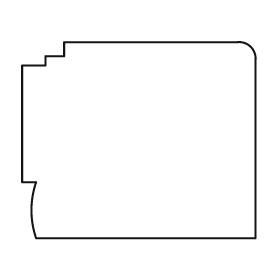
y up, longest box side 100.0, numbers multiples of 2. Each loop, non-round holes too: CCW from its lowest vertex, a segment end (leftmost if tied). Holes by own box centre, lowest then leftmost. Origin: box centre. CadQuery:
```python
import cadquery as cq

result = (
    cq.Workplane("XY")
    .moveTo(-44.0, -42.0)
    .lineTo(50.0, -42.0)
    .lineTo(50.0, 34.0)
    .threePointArc((48.0, 40.0), (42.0, 42.0))
    .lineTo(-32.0, 42.0)
    .lineTo(-32.0, 36.0)
    .lineTo(-40.0, 36.0)
    .lineTo(-40.0, 32.0)
    .lineTo(-50.0, 32.0)
    .lineTo(-50.0, -18.0)
    .lineTo(-44.0, -18.0)
    .threePointArc((-46.0, -30.0), (-44.0, -42.0))
    .close()
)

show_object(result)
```